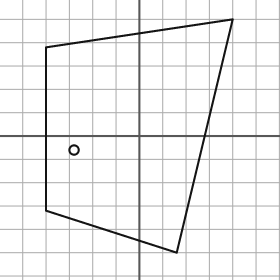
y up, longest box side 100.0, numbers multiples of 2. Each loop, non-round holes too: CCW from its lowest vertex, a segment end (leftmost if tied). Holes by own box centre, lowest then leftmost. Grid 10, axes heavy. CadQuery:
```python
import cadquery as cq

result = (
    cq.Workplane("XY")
    .moveTo(16.0, -50.0)
    .lineTo(40.0, 50.0)
    .lineTo(-40.0, 38.0)
    .lineTo(-40.0, -32.0)
    .close()
    .moveTo(-28.0, -6.0)
    .circle(2.0)
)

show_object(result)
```